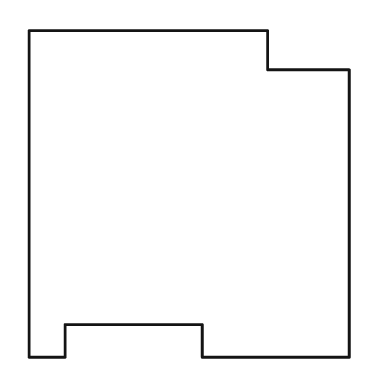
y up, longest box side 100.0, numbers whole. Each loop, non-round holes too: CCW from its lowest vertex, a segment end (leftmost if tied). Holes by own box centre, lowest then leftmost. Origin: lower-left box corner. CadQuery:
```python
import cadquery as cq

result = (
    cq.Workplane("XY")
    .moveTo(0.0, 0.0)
    .lineTo(11.0, 0.0)
    .lineTo(11.0, 10.0)
    .lineTo(53.0, 10.0)
    .lineTo(53.0, 0.0)
    .lineTo(98.0, 0.0)
    .lineTo(98.0, 88.0)
    .lineTo(73.0, 88.0)
    .lineTo(73.0, 100.0)
    .lineTo(0.0, 100.0)
    .close()
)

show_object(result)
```